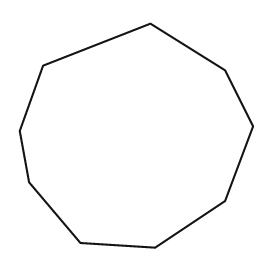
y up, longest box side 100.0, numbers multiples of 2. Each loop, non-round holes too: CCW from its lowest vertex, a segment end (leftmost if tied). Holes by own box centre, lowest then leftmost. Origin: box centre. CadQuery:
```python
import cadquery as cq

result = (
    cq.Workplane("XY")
    .moveTo(8.0, -48.0)
    .lineTo(38.0, -28.0)
    .lineTo(50.0, 4.0)
    .lineTo(38.0, 28.0)
    .lineTo(6.0, 48.0)
    .lineTo(-40.0, 30.0)
    .lineTo(-50.0, 2.0)
    .lineTo(-46.0, -20.0)
    .lineTo(-24.0, -46.0)
    .close()
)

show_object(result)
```